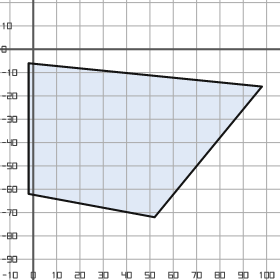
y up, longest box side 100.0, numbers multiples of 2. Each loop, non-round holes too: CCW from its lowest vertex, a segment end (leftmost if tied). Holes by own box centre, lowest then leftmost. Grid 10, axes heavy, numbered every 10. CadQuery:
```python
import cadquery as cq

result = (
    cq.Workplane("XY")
    .moveTo(52.0, -72.0)
    .lineTo(98.0, -16.0)
    .lineTo(-2.0, -6.0)
    .lineTo(-2.0, -62.0)
    .close()
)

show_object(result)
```